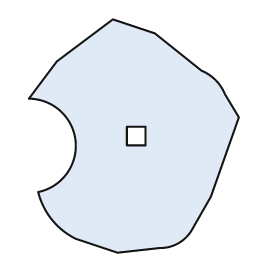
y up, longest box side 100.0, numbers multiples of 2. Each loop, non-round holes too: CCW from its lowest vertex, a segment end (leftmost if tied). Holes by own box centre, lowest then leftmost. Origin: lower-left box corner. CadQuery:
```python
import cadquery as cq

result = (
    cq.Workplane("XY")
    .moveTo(38.0, 0.0)
    .lineTo(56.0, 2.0)
    .threePointArc((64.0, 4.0), (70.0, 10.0))
    .lineTo(78.0, 24.0)
    .lineTo(90.0, 58.0)
    .lineTo(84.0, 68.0)
    .threePointArc((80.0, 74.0), (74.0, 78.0))
    .lineTo(54.0, 94.0)
    .lineTo(36.0, 100.0)
    .lineTo(12.0, 82.0)
    .lineTo(0.0, 66.0)
    .threePointArc((20.0, 48.0), (4.0, 26.0))
    .threePointArc((10.0, 14.0), (20.0, 6.0))
    .close()
    .moveTo(42.0, 46.0)
    .lineTo(50.0, 46.0)
    .lineTo(50.0, 54.0)
    .lineTo(42.0, 54.0)
    .close()
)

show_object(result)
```